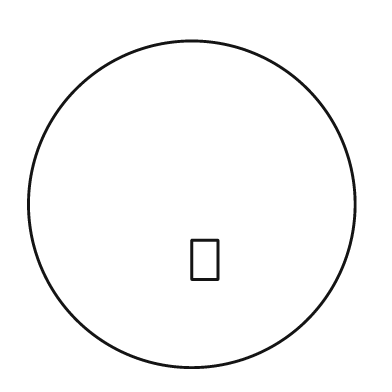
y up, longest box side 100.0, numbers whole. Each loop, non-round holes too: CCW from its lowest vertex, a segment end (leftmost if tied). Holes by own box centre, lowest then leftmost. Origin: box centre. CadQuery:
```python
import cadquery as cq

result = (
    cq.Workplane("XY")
    .moveTo(0.0, 0.0)
    .circle(50.0)
    .moveTo(0.0, -23.0)
    .lineTo(8.0, -23.0)
    .lineTo(8.0, -11.0)
    .lineTo(0.0, -11.0)
    .close()
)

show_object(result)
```